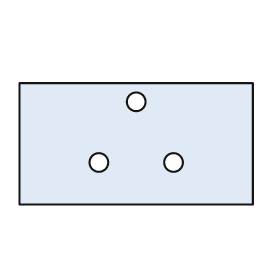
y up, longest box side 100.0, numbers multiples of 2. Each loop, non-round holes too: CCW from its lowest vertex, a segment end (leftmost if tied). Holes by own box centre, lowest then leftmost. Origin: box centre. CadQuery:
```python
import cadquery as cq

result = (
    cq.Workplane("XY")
    .moveTo(-50.0, -26.0)
    .lineTo(50.0, -26.0)
    .lineTo(50.0, 26.0)
    .lineTo(-50.0, 26.0)
    .close()
    .moveTo(-16.0, -8.0)
    .circle(4.0)
    .moveTo(16.0, -8.0)
    .circle(4.0)
    .moveTo(0.0, 18.0)
    .circle(4.0)
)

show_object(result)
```